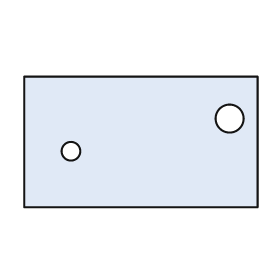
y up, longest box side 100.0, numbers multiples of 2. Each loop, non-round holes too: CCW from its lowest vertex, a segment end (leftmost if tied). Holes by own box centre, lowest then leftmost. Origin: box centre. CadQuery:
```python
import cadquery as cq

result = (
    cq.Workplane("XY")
    .moveTo(-50.0, -28.0)
    .lineTo(50.0, -28.0)
    .lineTo(50.0, 28.0)
    .lineTo(-50.0, 28.0)
    .close()
    .moveTo(-30.0, -4.0)
    .circle(4.0)
    .moveTo(38.0, 10.0)
    .circle(6.0)
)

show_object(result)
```